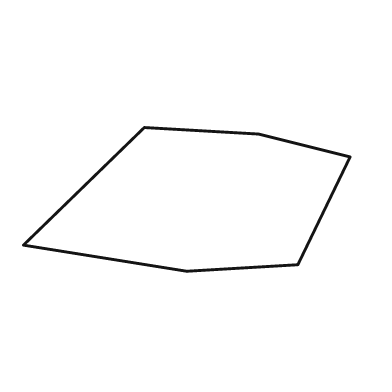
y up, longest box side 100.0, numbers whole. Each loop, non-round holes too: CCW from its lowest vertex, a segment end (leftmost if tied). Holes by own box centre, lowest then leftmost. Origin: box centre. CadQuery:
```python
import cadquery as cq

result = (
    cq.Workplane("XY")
    .moveTo(0.0, -22.0)
    .lineTo(34.0, -20.0)
    .lineTo(50.0, 13.0)
    .lineTo(22.0, 20.0)
    .lineTo(-13.0, 22.0)
    .lineTo(-50.0, -14.0)
    .close()
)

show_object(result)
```